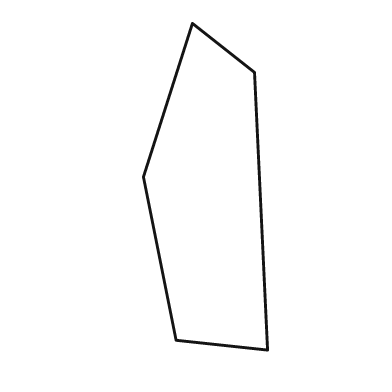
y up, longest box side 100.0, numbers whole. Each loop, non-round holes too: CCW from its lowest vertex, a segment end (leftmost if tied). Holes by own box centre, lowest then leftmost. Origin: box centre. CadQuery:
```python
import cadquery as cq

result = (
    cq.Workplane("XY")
    .moveTo(19.0, -50.0)
    .lineTo(15.0, 35.0)
    .lineTo(-4.0, 50.0)
    .lineTo(-19.0, 3.0)
    .lineTo(-9.0, -47.0)
    .close()
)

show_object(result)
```